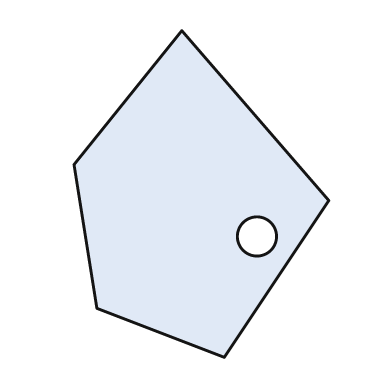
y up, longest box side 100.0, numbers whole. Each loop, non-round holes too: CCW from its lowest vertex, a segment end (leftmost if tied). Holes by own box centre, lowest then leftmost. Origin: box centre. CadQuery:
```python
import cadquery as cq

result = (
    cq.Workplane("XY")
    .moveTo(7.0, -50.0)
    .lineTo(39.0, -2.0)
    .lineTo(-6.0, 50.0)
    .lineTo(-39.0, 9.0)
    .lineTo(-32.0, -35.0)
    .close()
    .moveTo(17.0, -13.0)
    .circle(6.0)
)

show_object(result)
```